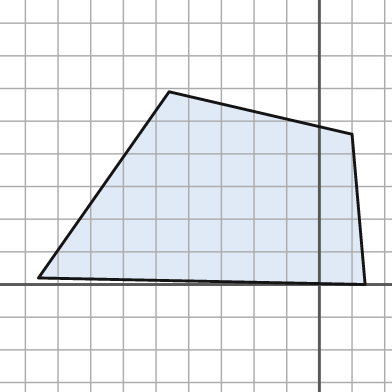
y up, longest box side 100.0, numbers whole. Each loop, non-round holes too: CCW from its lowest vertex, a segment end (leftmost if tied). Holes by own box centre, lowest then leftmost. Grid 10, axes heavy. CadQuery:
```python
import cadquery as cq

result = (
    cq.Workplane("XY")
    .moveTo(14.0, 0.0)
    .lineTo(10.0, 46.0)
    .lineTo(-46.0, 59.0)
    .lineTo(-86.0, 2.0)
    .close()
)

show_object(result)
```